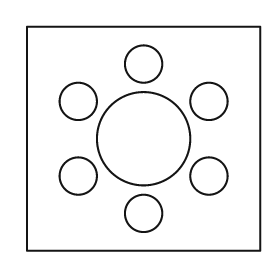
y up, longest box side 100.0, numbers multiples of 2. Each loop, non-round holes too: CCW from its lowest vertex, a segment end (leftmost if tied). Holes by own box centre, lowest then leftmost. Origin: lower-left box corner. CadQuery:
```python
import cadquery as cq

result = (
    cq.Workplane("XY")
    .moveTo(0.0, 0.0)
    .lineTo(100.0, 0.0)
    .lineTo(100.0, 96.0)
    .lineTo(0.0, 96.0)
    .close()
    .moveTo(50.0, 16.0)
    .circle(8.0)
    .moveTo(22.0, 32.0)
    .circle(8.0)
    .moveTo(78.0, 32.0)
    .circle(8.0)
    .moveTo(50.0, 48.0)
    .circle(20.0)
    .moveTo(22.0, 64.0)
    .circle(8.0)
    .moveTo(78.0, 64.0)
    .circle(8.0)
    .moveTo(50.0, 80.0)
    .circle(8.0)
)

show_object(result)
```